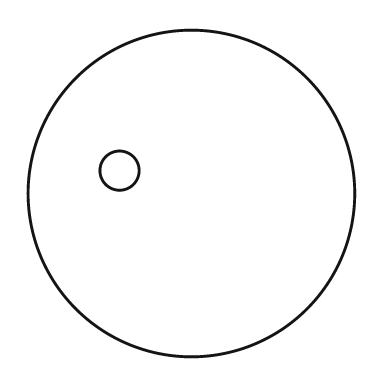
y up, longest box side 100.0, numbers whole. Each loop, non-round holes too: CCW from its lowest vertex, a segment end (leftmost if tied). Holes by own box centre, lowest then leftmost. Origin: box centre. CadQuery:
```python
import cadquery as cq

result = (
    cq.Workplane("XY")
    .moveTo(0.0, 0.0)
    .circle(50.0)
    .moveTo(-22.0, 7.0)
    .circle(6.0)
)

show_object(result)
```